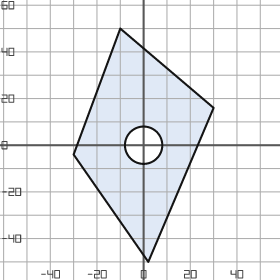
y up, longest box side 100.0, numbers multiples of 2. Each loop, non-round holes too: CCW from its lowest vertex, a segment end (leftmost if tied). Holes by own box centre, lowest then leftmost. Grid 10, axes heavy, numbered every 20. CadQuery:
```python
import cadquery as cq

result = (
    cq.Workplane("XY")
    .moveTo(2.0, -50.0)
    .lineTo(30.0, 16.0)
    .lineTo(-10.0, 50.0)
    .lineTo(-30.0, -4.0)
    .close()
    .moveTo(0.0, 0.0)
    .circle(8.0)
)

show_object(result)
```